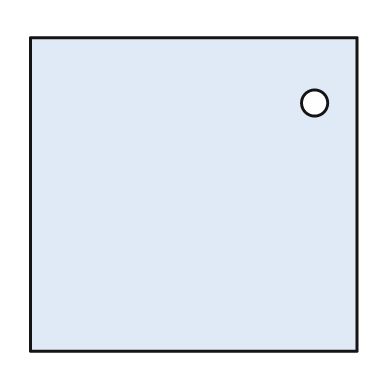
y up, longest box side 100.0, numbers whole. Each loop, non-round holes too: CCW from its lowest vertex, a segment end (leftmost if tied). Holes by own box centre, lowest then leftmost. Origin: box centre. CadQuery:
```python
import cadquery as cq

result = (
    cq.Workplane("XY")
    .moveTo(-50.0, -48.0)
    .lineTo(50.0, -48.0)
    .lineTo(50.0, 48.0)
    .lineTo(-50.0, 48.0)
    .close()
    .moveTo(37.0, 28.0)
    .circle(4.0)
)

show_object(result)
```